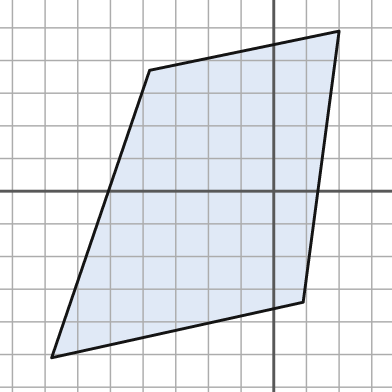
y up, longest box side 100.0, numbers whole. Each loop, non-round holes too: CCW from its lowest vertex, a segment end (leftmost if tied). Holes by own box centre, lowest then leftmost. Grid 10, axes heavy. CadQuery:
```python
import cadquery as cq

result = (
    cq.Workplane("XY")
    .moveTo(-68.0, -51.0)
    .lineTo(9.0, -34.0)
    .lineTo(20.0, 49.0)
    .lineTo(-38.0, 37.0)
    .close()
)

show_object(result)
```